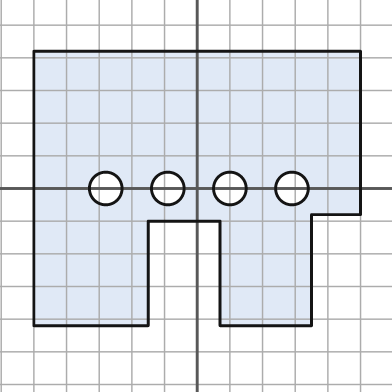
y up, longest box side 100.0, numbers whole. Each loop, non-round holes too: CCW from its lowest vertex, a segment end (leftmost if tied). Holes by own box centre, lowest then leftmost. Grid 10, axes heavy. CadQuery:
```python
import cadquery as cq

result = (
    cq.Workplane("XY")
    .moveTo(-50.0, -42.0)
    .lineTo(-15.0, -42.0)
    .lineTo(-15.0, -10.0)
    .lineTo(7.0, -10.0)
    .lineTo(7.0, -42.0)
    .lineTo(35.0, -42.0)
    .lineTo(35.0, -8.0)
    .lineTo(50.0, -8.0)
    .lineTo(50.0, 42.0)
    .lineTo(-50.0, 42.0)
    .close()
    .moveTo(-28.0, 0.0)
    .circle(5.0)
    .moveTo(-9.0, 0.0)
    .circle(5.0)
    .moveTo(10.0, 0.0)
    .circle(5.0)
    .moveTo(29.0, 0.0)
    .circle(5.0)
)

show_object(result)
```